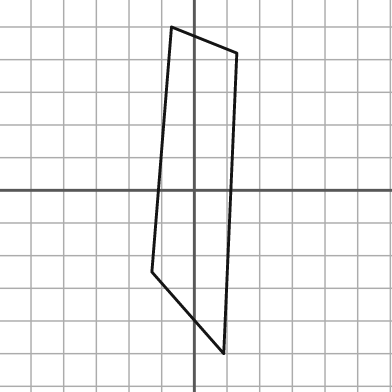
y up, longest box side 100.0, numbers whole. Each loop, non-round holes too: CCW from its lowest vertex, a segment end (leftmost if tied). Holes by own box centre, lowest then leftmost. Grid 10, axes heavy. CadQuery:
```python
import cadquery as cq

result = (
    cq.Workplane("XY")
    .moveTo(9.0, -50.0)
    .lineTo(13.0, 42.0)
    .lineTo(-7.0, 50.0)
    .lineTo(-13.0, -25.0)
    .close()
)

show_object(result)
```